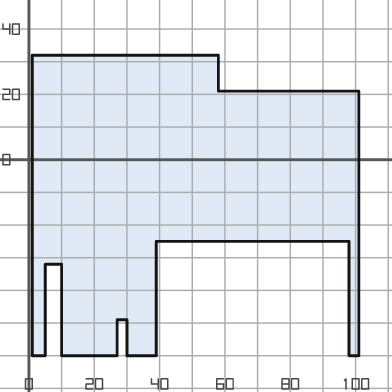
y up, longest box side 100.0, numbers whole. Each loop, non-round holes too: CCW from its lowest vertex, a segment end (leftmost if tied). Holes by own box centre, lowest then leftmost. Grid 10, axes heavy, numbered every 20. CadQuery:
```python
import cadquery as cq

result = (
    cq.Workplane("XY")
    .moveTo(1.0, -60.0)
    .lineTo(5.0, -60.0)
    .lineTo(5.0, -32.0)
    .lineTo(10.0, -32.0)
    .lineTo(10.0, -60.0)
    .lineTo(27.0, -60.0)
    .lineTo(27.0, -49.0)
    .lineTo(30.0, -49.0)
    .lineTo(30.0, -60.0)
    .lineTo(39.0, -60.0)
    .lineTo(39.0, -25.0)
    .lineTo(98.0, -25.0)
    .lineTo(98.0, -60.0)
    .lineTo(101.0, -60.0)
    .lineTo(101.0, 21.0)
    .lineTo(58.0, 21.0)
    .lineTo(58.0, 32.0)
    .lineTo(1.0, 32.0)
    .close()
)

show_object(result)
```